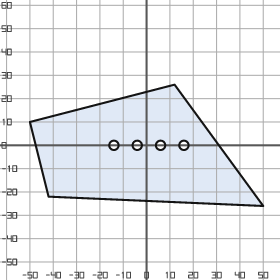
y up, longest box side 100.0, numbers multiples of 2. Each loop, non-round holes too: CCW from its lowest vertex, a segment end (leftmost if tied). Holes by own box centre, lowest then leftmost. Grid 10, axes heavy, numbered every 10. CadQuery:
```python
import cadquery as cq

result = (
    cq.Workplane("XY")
    .moveTo(50.0, -26.0)
    .lineTo(12.0, 26.0)
    .lineTo(-50.0, 10.0)
    .lineTo(-42.0, -22.0)
    .close()
    .moveTo(-14.0, 0.0)
    .circle(2.0)
    .moveTo(-4.0, 0.0)
    .circle(2.0)
    .moveTo(6.0, 0.0)
    .circle(2.0)
    .moveTo(16.0, 0.0)
    .circle(2.0)
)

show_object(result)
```